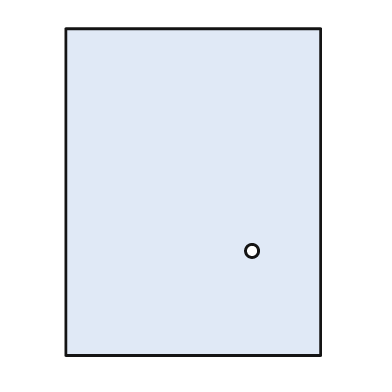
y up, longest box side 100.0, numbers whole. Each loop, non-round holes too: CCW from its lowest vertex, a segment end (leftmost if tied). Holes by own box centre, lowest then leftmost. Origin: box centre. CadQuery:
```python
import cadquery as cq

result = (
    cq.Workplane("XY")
    .moveTo(-39.0, -50.0)
    .lineTo(39.0, -50.0)
    .lineTo(39.0, 50.0)
    .lineTo(-39.0, 50.0)
    .close()
    .moveTo(18.0, -18.0)
    .circle(2.0)
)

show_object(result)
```